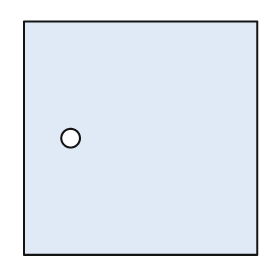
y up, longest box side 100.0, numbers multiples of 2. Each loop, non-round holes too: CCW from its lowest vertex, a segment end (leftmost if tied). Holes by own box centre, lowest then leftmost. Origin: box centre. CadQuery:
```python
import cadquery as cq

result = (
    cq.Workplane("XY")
    .moveTo(-50.0, -50.0)
    .lineTo(50.0, -50.0)
    .lineTo(50.0, 50.0)
    .lineTo(-50.0, 50.0)
    .close()
    .moveTo(-30.0, 0.0)
    .circle(4.0)
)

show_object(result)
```